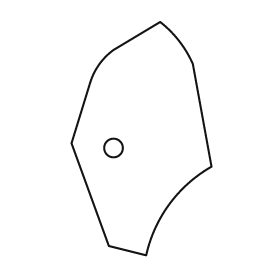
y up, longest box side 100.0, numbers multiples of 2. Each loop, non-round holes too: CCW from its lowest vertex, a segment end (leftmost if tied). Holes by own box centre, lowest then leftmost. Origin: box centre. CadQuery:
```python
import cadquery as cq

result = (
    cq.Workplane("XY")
    .moveTo(2.0, -50.0)
    .threePointArc((12.0, -28.0), (30.0, -12.0))
    .lineTo(22.0, 32.0)
    .threePointArc((16.0, 42.0), (8.0, 50.0))
    .lineTo(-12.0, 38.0)
    .threePointArc((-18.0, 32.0), (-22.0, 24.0))
    .lineTo(-30.0, -2.0)
    .lineTo(-14.0, -46.0)
    .close()
    .moveTo(-12.0, -4.0)
    .circle(4.0)
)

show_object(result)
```